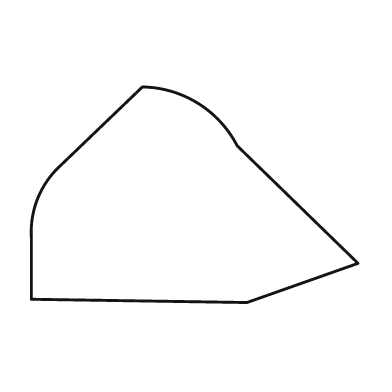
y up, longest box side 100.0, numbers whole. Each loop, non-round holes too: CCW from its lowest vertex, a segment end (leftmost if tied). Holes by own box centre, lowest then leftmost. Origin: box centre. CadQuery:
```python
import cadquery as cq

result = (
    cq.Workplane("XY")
    .moveTo(16.0, -33.0)
    .lineTo(50.0, -21.0)
    .lineTo(13.0, 15.0)
    .threePointArc((1.0, 28.0), (-16.0, 33.0))
    .lineTo(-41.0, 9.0)
    .threePointArc((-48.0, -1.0), (-50.0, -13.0))
    .lineTo(-50.0, -32.0)
    .close()
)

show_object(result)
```